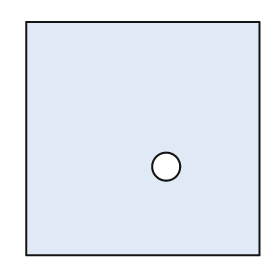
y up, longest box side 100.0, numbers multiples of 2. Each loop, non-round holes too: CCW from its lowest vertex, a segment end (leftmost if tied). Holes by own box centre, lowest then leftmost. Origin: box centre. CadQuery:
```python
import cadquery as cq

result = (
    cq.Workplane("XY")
    .moveTo(-50.0, -50.0)
    .lineTo(50.0, -50.0)
    .lineTo(50.0, 50.0)
    .lineTo(-50.0, 50.0)
    .close()
    .moveTo(10.0, -12.0)
    .circle(6.0)
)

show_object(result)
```